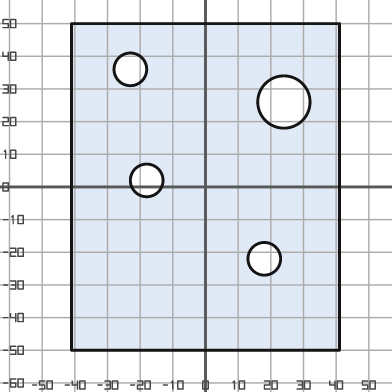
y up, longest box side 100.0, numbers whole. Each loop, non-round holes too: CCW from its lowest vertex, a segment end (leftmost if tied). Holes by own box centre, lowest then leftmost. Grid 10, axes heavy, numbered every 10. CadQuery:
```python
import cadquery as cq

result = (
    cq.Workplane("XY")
    .moveTo(-41.0, -50.0)
    .lineTo(41.0, -50.0)
    .lineTo(41.0, 50.0)
    .lineTo(-41.0, 50.0)
    .close()
    .moveTo(18.0, -22.0)
    .circle(5.0)
    .moveTo(-18.0, 2.0)
    .circle(5.0)
    .moveTo(24.0, 26.0)
    .circle(8.0)
    .moveTo(-23.0, 36.0)
    .circle(5.0)
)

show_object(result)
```